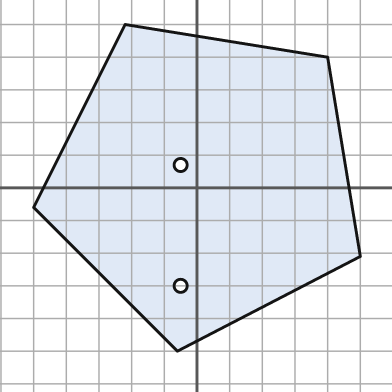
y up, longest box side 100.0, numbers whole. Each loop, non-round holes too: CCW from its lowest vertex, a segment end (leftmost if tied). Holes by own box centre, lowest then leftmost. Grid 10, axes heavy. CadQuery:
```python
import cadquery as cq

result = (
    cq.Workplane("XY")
    .moveTo(-6.0, -50.0)
    .lineTo(50.0, -21.0)
    .lineTo(40.0, 40.0)
    .lineTo(-22.0, 50.0)
    .lineTo(-50.0, -6.0)
    .close()
    .moveTo(-5.0, -30.0)
    .circle(2.0)
    .moveTo(-5.0, 7.0)
    .circle(2.0)
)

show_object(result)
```